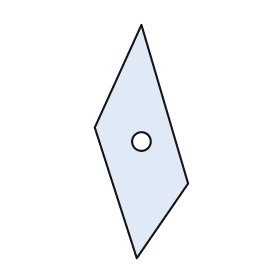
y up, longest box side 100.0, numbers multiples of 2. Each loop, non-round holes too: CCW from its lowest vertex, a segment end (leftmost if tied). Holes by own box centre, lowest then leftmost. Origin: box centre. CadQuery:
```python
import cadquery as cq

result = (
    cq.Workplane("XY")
    .moveTo(-2.0, -50.0)
    .lineTo(20.0, -18.0)
    .lineTo(0.0, 50.0)
    .lineTo(-20.0, 6.0)
    .close()
    .moveTo(0.0, 0.0)
    .circle(4.0)
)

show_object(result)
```